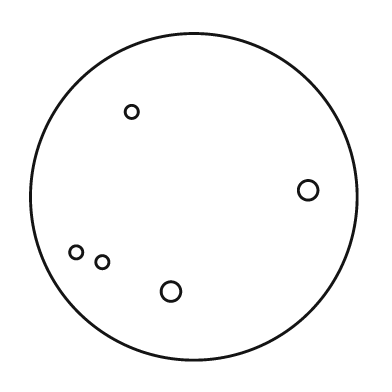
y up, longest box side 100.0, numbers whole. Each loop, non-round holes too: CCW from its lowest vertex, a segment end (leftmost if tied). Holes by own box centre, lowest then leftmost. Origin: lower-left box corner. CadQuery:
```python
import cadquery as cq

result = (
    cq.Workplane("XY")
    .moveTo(50.0, 50.0)
    .circle(50.0)
    .moveTo(43.0, 21.0)
    .circle(3.0)
    .moveTo(22.0, 30.0)
    .circle(2.0)
    .moveTo(14.0, 33.0)
    .circle(2.0)
    .moveTo(85.0, 52.0)
    .circle(3.0)
    .moveTo(31.0, 76.0)
    .circle(2.0)
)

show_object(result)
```